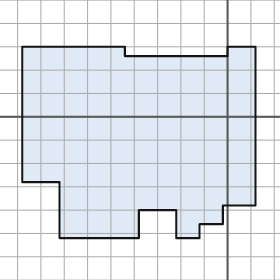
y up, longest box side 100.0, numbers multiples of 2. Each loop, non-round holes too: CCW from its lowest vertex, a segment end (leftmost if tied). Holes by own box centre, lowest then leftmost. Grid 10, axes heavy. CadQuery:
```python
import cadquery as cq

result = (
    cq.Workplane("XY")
    .moveTo(-72.0, -52.0)
    .lineTo(-38.0, -52.0)
    .lineTo(-38.0, -40.0)
    .lineTo(-22.0, -40.0)
    .lineTo(-22.0, -52.0)
    .lineTo(-12.0, -52.0)
    .lineTo(-12.0, -46.0)
    .lineTo(-2.0, -46.0)
    .lineTo(-2.0, -38.0)
    .lineTo(12.0, -38.0)
    .lineTo(12.0, 30.0)
    .lineTo(0.0, 30.0)
    .lineTo(0.0, 26.0)
    .lineTo(-44.0, 26.0)
    .lineTo(-44.0, 30.0)
    .lineTo(-88.0, 30.0)
    .lineTo(-88.0, -28.0)
    .lineTo(-72.0, -28.0)
    .close()
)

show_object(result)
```